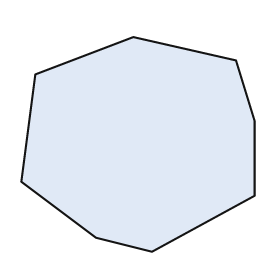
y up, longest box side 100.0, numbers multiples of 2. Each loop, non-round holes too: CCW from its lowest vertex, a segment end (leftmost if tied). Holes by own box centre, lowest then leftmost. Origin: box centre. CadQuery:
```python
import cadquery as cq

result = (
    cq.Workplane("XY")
    .moveTo(6.0, -46.0)
    .lineTo(50.0, -22.0)
    .lineTo(50.0, 10.0)
    .lineTo(42.0, 36.0)
    .lineTo(-2.0, 46.0)
    .lineTo(-44.0, 30.0)
    .lineTo(-50.0, -16.0)
    .lineTo(-18.0, -40.0)
    .close()
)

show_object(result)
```